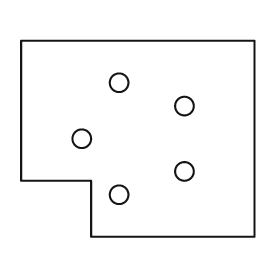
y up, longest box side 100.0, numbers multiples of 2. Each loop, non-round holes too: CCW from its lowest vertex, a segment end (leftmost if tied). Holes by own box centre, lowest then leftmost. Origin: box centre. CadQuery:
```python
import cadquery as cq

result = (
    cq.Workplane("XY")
    .moveTo(-20.0, -42.0)
    .lineTo(50.0, -42.0)
    .lineTo(50.0, 42.0)
    .lineTo(-50.0, 42.0)
    .lineTo(-50.0, -18.0)
    .lineTo(-20.0, -18.0)
    .close()
    .moveTo(-8.0, -24.0)
    .circle(4.0)
    .moveTo(20.0, -14.0)
    .circle(4.0)
    .moveTo(-24.0, 0.0)
    .circle(4.0)
    .moveTo(20.0, 14.0)
    .circle(4.0)
    .moveTo(-8.0, 24.0)
    .circle(4.0)
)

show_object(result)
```